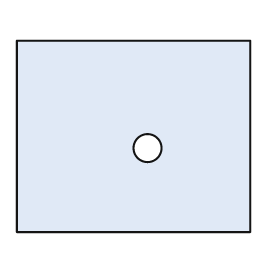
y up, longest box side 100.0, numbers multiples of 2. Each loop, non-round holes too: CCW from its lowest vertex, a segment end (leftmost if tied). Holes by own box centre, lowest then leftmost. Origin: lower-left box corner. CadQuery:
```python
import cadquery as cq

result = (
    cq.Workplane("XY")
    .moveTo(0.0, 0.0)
    .lineTo(100.0, 0.0)
    .lineTo(100.0, 82.0)
    .lineTo(0.0, 82.0)
    .close()
    .moveTo(56.0, 36.0)
    .circle(6.0)
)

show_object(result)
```